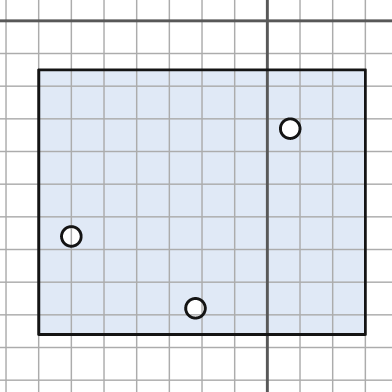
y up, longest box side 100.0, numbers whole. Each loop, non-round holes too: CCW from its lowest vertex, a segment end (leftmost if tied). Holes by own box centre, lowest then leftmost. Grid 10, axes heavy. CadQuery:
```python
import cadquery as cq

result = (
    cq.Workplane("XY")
    .moveTo(-70.0, -96.0)
    .lineTo(30.0, -96.0)
    .lineTo(30.0, -15.0)
    .lineTo(-70.0, -15.0)
    .close()
    .moveTo(-22.0, -88.0)
    .circle(3.0)
    .moveTo(-60.0, -66.0)
    .circle(3.0)
    .moveTo(7.0, -33.0)
    .circle(3.0)
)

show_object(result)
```